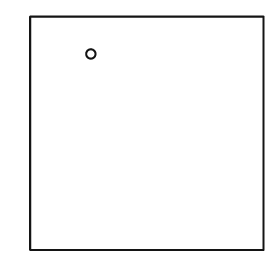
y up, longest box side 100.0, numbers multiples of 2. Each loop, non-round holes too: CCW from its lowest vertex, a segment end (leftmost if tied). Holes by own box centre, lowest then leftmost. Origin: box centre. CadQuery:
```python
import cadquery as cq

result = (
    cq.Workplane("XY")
    .moveTo(-50.0, -50.0)
    .lineTo(50.0, -50.0)
    .lineTo(50.0, 50.0)
    .lineTo(-50.0, 50.0)
    .close()
    .moveTo(-24.0, 34.0)
    .circle(2.0)
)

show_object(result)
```